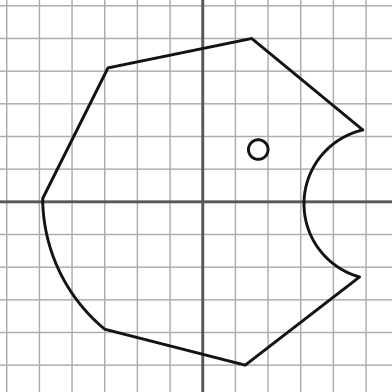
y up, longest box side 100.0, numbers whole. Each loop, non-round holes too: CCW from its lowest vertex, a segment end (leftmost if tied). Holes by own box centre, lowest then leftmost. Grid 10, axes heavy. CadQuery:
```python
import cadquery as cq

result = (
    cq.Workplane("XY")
    .moveTo(13.0, -50.0)
    .lineTo(48.0, -23.0)
    .threePointArc((31.0, 0.0), (49.0, 22.0))
    .lineTo(15.0, 50.0)
    .lineTo(-29.0, 41.0)
    .lineTo(-49.0, 1.0)
    .threePointArc((-44.0, -21.0), (-30.0, -39.0))
    .close()
    .moveTo(17.0, 16.0)
    .circle(3.0)
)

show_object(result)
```